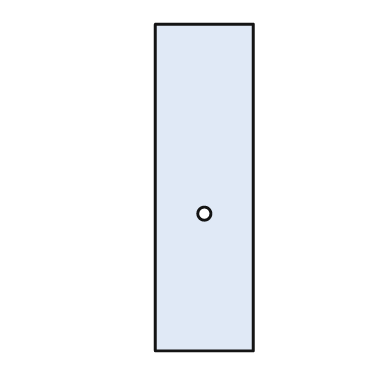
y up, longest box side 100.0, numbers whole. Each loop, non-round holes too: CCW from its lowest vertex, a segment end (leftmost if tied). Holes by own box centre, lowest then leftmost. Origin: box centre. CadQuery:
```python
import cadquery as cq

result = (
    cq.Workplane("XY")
    .moveTo(-15.0, -50.0)
    .lineTo(15.0, -50.0)
    .lineTo(15.0, 50.0)
    .lineTo(-15.0, 50.0)
    .close()
    .moveTo(0.0, -8.0)
    .circle(2.0)
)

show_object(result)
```